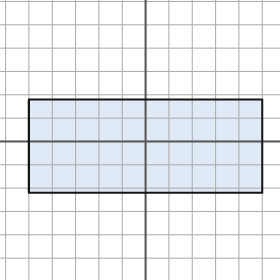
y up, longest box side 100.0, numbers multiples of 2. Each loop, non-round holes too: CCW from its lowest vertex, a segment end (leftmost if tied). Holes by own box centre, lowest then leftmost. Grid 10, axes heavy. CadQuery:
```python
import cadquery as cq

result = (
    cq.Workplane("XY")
    .moveTo(-50.0, -22.0)
    .lineTo(50.0, -22.0)
    .lineTo(50.0, 18.0)
    .lineTo(-50.0, 18.0)
    .close()
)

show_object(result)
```